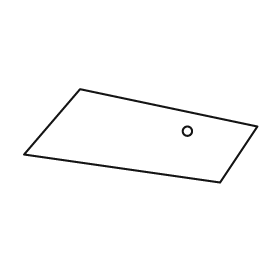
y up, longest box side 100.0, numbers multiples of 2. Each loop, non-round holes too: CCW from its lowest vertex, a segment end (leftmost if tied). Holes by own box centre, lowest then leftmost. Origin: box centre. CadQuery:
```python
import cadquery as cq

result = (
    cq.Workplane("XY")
    .moveTo(34.0, -20.0)
    .lineTo(50.0, 4.0)
    .lineTo(-26.0, 20.0)
    .lineTo(-50.0, -8.0)
    .close()
    .moveTo(20.0, 2.0)
    .circle(2.0)
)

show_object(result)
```